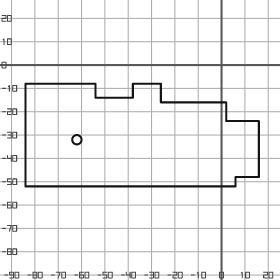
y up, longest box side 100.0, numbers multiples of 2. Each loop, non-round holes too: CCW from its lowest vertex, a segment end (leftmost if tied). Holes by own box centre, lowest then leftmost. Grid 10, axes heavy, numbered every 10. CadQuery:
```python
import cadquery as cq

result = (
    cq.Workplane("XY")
    .moveTo(-84.0, -52.0)
    .lineTo(6.0, -52.0)
    .lineTo(6.0, -48.0)
    .lineTo(16.0, -48.0)
    .lineTo(16.0, -24.0)
    .lineTo(2.0, -24.0)
    .lineTo(2.0, -16.0)
    .lineTo(-26.0, -16.0)
    .lineTo(-26.0, -8.0)
    .lineTo(-38.0, -8.0)
    .lineTo(-38.0, -14.0)
    .lineTo(-54.0, -14.0)
    .lineTo(-54.0, -8.0)
    .lineTo(-84.0, -8.0)
    .close()
    .moveTo(-62.0, -32.0)
    .circle(2.0)
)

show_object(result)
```